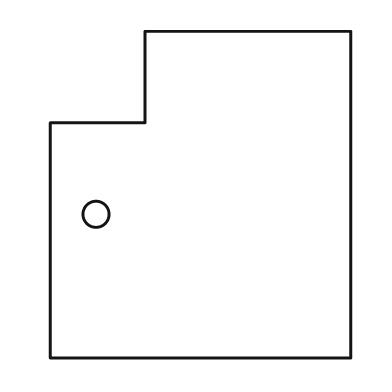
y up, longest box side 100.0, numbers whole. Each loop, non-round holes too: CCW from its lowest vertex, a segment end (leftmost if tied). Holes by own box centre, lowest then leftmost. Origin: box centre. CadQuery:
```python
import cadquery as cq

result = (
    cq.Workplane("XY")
    .moveTo(-46.0, -50.0)
    .lineTo(46.0, -50.0)
    .lineTo(46.0, 50.0)
    .lineTo(-17.0, 50.0)
    .lineTo(-17.0, 22.0)
    .lineTo(-46.0, 22.0)
    .close()
    .moveTo(-32.0, -6.0)
    .circle(4.0)
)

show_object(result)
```